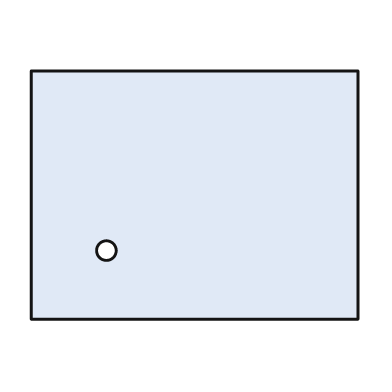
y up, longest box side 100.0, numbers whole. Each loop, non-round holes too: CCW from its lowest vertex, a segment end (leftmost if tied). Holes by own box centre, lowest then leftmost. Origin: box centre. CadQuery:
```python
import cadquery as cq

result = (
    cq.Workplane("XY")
    .moveTo(-50.0, -38.0)
    .lineTo(50.0, -38.0)
    .lineTo(50.0, 38.0)
    .lineTo(-50.0, 38.0)
    .close()
    .moveTo(-27.0, -17.0)
    .circle(3.0)
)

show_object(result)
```